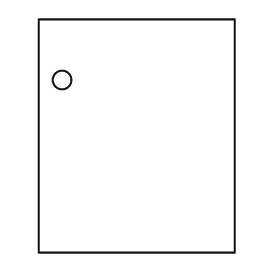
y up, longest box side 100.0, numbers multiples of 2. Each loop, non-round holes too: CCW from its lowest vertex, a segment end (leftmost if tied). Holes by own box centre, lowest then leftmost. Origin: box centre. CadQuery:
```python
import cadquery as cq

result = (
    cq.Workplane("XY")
    .moveTo(-42.0, -50.0)
    .lineTo(42.0, -50.0)
    .lineTo(42.0, 50.0)
    .lineTo(-42.0, 50.0)
    .close()
    .moveTo(-32.0, 24.0)
    .circle(4.0)
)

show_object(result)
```